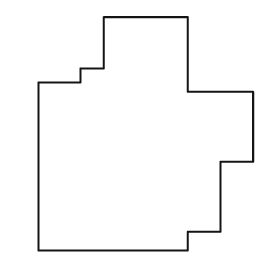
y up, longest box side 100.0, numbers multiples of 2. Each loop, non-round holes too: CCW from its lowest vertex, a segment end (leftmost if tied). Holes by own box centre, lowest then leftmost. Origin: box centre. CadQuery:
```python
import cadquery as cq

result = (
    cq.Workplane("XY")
    .moveTo(-46.0, -50.0)
    .lineTo(18.0, -50.0)
    .lineTo(18.0, -42.0)
    .lineTo(32.0, -42.0)
    .lineTo(32.0, -12.0)
    .lineTo(46.0, -12.0)
    .lineTo(46.0, 18.0)
    .lineTo(18.0, 18.0)
    .lineTo(18.0, 50.0)
    .lineTo(-18.0, 50.0)
    .lineTo(-18.0, 28.0)
    .lineTo(-28.0, 28.0)
    .lineTo(-28.0, 22.0)
    .lineTo(-46.0, 22.0)
    .close()
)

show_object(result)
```